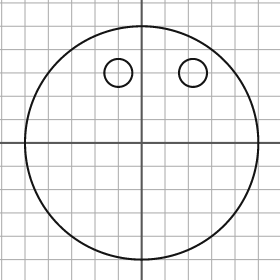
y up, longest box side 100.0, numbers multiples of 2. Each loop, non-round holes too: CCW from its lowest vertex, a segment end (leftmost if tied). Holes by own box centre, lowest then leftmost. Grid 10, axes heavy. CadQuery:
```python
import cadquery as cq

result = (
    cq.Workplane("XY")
    .moveTo(0.0, 0.0)
    .circle(50.0)
    .moveTo(-10.0, 30.0)
    .circle(6.0)
    .moveTo(22.0, 30.0)
    .circle(6.0)
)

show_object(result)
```